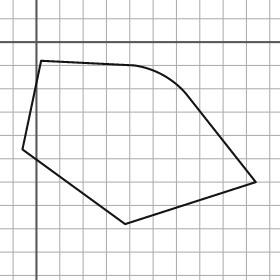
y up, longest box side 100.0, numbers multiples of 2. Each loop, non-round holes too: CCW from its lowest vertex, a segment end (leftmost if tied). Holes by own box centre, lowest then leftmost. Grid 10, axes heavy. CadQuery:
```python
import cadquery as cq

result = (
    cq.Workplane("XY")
    .moveTo(38.0, -78.0)
    .lineTo(94.0, -60.0)
    .lineTo(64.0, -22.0)
    .threePointArc((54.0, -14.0), (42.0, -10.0))
    .lineTo(2.0, -8.0)
    .lineTo(-6.0, -46.0)
    .close()
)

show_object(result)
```